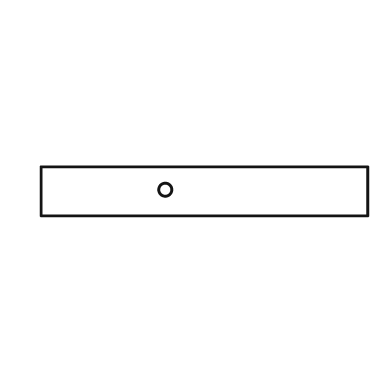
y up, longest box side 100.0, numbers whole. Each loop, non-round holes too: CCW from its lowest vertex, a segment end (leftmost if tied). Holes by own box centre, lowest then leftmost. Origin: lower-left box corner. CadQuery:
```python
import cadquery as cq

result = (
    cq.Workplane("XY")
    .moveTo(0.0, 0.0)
    .lineTo(100.0, 0.0)
    .lineTo(100.0, 15.0)
    .lineTo(0.0, 15.0)
    .close()
    .moveTo(38.0, 8.0)
    .circle(2.0)
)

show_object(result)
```